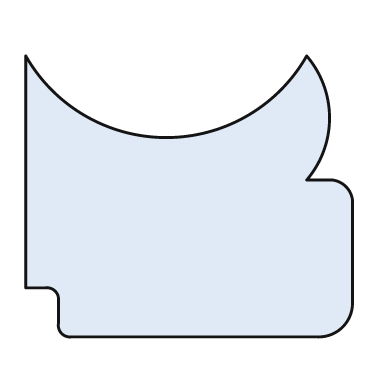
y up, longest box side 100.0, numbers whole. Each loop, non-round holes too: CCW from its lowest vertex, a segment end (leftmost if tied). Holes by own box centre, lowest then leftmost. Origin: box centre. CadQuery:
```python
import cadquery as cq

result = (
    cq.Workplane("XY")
    .moveTo(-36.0, -43.0)
    .lineTo(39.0, -43.0)
    .threePointArc((47.0, -40.0), (50.0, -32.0))
    .lineTo(50.0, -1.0)
    .threePointArc((48.0, 3.0), (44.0, 5.0))
    .lineTo(36.0, 5.0)
    .threePointArc((43.0, 24.0), (36.0, 43.0))
    .threePointArc((-7.0, 18.0), (-50.0, 43.0))
    .lineTo(-50.0, -28.0)
    .lineTo(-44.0, -28.0)
    .threePointArc((-41.0, -29.0), (-40.0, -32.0))
    .lineTo(-40.0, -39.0)
    .threePointArc((-39.0, -42.0), (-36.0, -43.0))
    .close()
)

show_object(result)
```